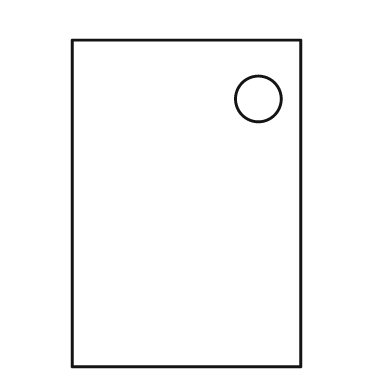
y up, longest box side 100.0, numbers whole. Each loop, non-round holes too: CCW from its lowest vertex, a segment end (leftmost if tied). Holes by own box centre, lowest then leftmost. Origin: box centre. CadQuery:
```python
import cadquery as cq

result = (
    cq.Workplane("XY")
    .moveTo(-35.0, -50.0)
    .lineTo(35.0, -50.0)
    .lineTo(35.0, 50.0)
    .lineTo(-35.0, 50.0)
    .close()
    .moveTo(22.0, 32.0)
    .circle(7.0)
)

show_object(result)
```